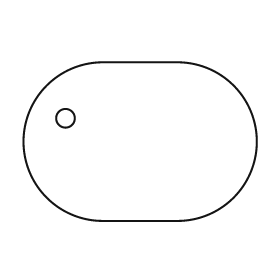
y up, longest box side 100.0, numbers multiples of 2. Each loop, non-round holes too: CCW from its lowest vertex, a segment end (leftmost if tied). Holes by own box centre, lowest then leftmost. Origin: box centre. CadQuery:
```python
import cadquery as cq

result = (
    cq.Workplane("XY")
    .moveTo(-16.0, -34.0)
    .lineTo(16.0, -34.0)
    .threePointArc((50.0, 0.0), (16.0, 34.0))
    .lineTo(-16.0, 34.0)
    .threePointArc((-50.0, 0.0), (-16.0, -34.0))
    .close()
    .moveTo(-32.0, 10.0)
    .circle(4.0)
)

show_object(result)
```